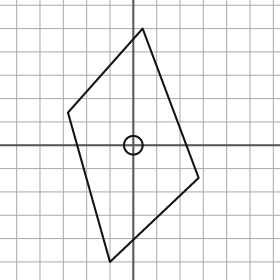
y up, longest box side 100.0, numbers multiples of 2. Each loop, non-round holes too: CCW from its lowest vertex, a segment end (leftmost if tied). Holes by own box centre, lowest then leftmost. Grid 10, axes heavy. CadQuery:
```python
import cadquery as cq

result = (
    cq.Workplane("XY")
    .moveTo(-10.0, -50.0)
    .lineTo(28.0, -14.0)
    .lineTo(4.0, 50.0)
    .lineTo(-28.0, 14.0)
    .close()
    .moveTo(0.0, 0.0)
    .circle(4.0)
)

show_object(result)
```